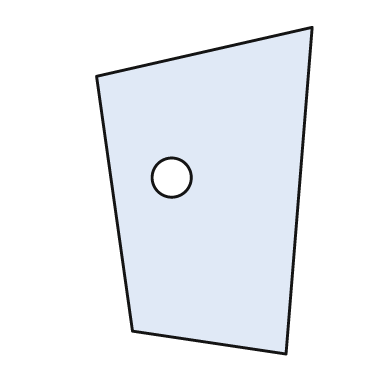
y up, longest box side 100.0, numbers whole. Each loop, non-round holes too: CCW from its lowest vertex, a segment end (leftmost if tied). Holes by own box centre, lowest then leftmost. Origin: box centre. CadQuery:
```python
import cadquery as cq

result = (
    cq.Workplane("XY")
    .moveTo(25.0, -50.0)
    .lineTo(33.0, 50.0)
    .lineTo(-33.0, 35.0)
    .lineTo(-22.0, -43.0)
    .close()
    .moveTo(-10.0, 4.0)
    .circle(6.0)
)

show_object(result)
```